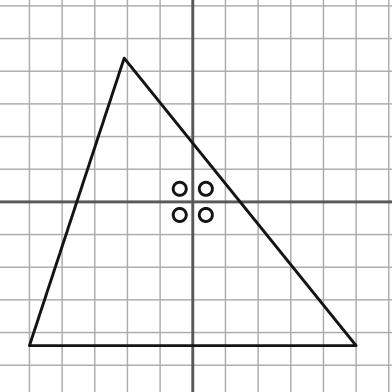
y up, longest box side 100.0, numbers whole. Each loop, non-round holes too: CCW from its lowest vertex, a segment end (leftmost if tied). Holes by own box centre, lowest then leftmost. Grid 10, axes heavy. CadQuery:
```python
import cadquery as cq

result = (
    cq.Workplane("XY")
    .moveTo(-50.0, -44.0)
    .lineTo(50.0, -44.0)
    .lineTo(-21.0, 44.0)
    .close()
    .moveTo(-4.0, -4.0)
    .circle(2.0)
    .moveTo(4.0, -4.0)
    .circle(2.0)
    .moveTo(-4.0, 4.0)
    .circle(2.0)
    .moveTo(4.0, 4.0)
    .circle(2.0)
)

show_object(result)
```